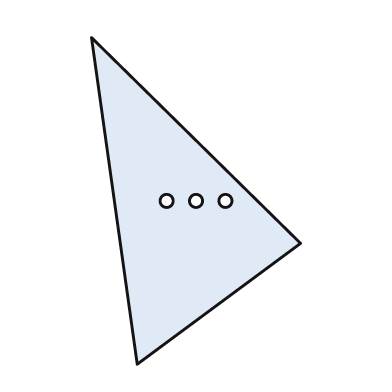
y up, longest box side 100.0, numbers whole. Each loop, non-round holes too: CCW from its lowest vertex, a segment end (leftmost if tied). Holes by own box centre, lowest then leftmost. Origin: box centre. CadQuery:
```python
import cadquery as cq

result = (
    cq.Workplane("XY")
    .moveTo(-18.0, -50.0)
    .lineTo(32.0, -13.0)
    .lineTo(-32.0, 50.0)
    .close()
    .moveTo(-9.0, 0.0)
    .circle(2.0)
    .moveTo(0.0, 0.0)
    .circle(2.0)
    .moveTo(9.0, 0.0)
    .circle(2.0)
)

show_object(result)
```